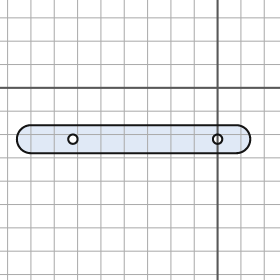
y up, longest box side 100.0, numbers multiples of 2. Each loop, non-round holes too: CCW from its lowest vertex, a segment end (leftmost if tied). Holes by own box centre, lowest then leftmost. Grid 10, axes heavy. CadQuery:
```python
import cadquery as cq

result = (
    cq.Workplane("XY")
    .moveTo(-80.0, -28.0)
    .lineTo(8.0, -28.0)
    .threePointArc((14.0, -22.0), (8.0, -16.0))
    .lineTo(-80.0, -16.0)
    .threePointArc((-86.0, -22.0), (-80.0, -28.0))
    .close()
    .moveTo(-62.0, -22.0)
    .circle(2.0)
    .moveTo(0.0, -22.0)
    .circle(2.0)
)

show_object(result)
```